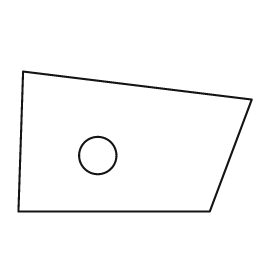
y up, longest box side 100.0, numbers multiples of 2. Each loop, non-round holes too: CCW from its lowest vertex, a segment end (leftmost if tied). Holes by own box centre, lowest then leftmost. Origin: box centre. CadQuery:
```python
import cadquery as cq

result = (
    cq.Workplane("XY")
    .moveTo(-50.0, -30.0)
    .lineTo(32.0, -30.0)
    .lineTo(50.0, 18.0)
    .lineTo(-48.0, 30.0)
    .close()
    .moveTo(-16.0, -6.0)
    .circle(8.0)
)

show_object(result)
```